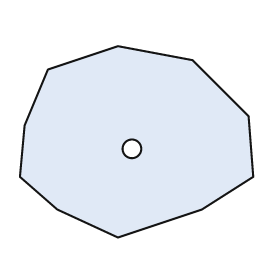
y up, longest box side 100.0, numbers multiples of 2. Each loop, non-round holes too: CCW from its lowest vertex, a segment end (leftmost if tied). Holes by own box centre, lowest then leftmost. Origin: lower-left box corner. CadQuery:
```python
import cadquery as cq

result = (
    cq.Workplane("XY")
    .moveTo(42.0, 0.0)
    .lineTo(78.0, 12.0)
    .lineTo(100.0, 26.0)
    .lineTo(98.0, 52.0)
    .lineTo(74.0, 76.0)
    .lineTo(42.0, 82.0)
    .lineTo(12.0, 72.0)
    .lineTo(2.0, 48.0)
    .lineTo(0.0, 26.0)
    .lineTo(16.0, 12.0)
    .close()
    .moveTo(48.0, 38.0)
    .circle(4.0)
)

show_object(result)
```